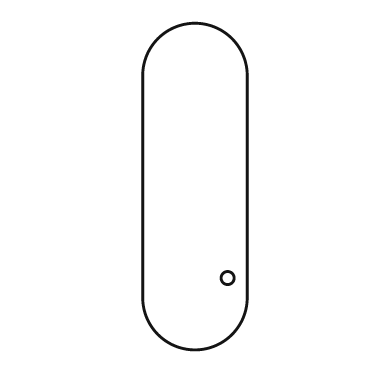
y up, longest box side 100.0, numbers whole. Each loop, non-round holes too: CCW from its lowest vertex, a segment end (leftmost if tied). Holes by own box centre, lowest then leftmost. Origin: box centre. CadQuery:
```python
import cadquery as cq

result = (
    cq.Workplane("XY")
    .moveTo(-16.0, -34.0)
    .threePointArc((0.0, -50.0), (16.0, -34.0))
    .lineTo(16.0, 34.0)
    .threePointArc((0.0, 50.0), (-16.0, 34.0))
    .close()
    .moveTo(10.0, -28.0)
    .circle(2.0)
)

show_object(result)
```